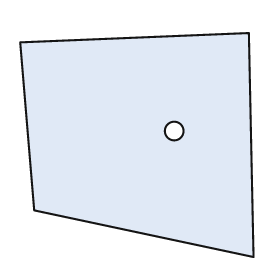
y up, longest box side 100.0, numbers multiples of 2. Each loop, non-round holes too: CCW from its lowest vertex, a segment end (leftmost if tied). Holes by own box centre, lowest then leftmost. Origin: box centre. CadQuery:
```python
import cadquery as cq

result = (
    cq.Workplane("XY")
    .moveTo(50.0, -48.0)
    .lineTo(48.0, 48.0)
    .lineTo(-50.0, 44.0)
    .lineTo(-44.0, -28.0)
    .close()
    .moveTo(16.0, 6.0)
    .circle(4.0)
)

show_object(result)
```